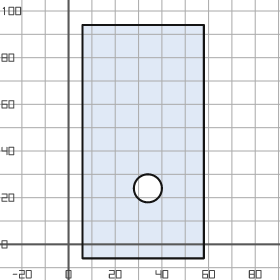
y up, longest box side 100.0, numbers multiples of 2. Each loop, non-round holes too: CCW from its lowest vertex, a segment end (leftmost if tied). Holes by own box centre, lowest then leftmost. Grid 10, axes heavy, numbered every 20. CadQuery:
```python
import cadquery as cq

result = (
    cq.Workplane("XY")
    .moveTo(6.0, -6.0)
    .lineTo(58.0, -6.0)
    .lineTo(58.0, 94.0)
    .lineTo(6.0, 94.0)
    .close()
    .moveTo(34.0, 24.0)
    .circle(6.0)
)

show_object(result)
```